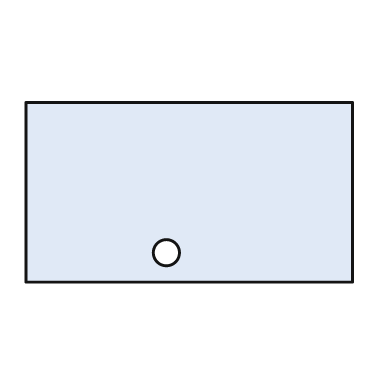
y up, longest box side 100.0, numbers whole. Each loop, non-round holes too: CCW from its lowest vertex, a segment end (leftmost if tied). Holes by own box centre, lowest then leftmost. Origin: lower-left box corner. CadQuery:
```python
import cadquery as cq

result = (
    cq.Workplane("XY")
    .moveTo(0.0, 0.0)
    .lineTo(100.0, 0.0)
    .lineTo(100.0, 55.0)
    .lineTo(0.0, 55.0)
    .close()
    .moveTo(43.0, 9.0)
    .circle(4.0)
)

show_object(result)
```